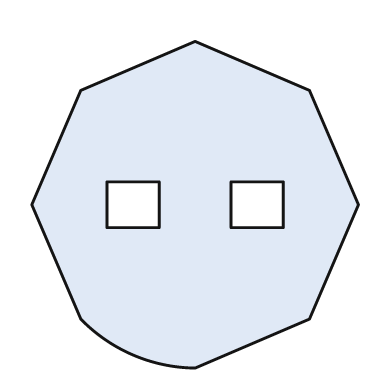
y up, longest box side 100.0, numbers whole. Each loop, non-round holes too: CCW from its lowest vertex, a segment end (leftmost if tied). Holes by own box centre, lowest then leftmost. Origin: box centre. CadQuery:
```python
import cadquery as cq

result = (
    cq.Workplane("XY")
    .moveTo(0.0, -50.0)
    .lineTo(35.0, -35.0)
    .lineTo(50.0, 0.0)
    .lineTo(35.0, 35.0)
    .lineTo(0.0, 50.0)
    .lineTo(-35.0, 35.0)
    .lineTo(-50.0, 0.0)
    .lineTo(-35.0, -35.0)
    .threePointArc((-19.0, -46.0), (0.0, -50.0))
    .close()
    .moveTo(-27.0, -7.0)
    .lineTo(-11.0, -7.0)
    .lineTo(-11.0, 7.0)
    .lineTo(-27.0, 7.0)
    .close()
    .moveTo(11.0, -7.0)
    .lineTo(27.0, -7.0)
    .lineTo(27.0, 7.0)
    .lineTo(11.0, 7.0)
    .close()
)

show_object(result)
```